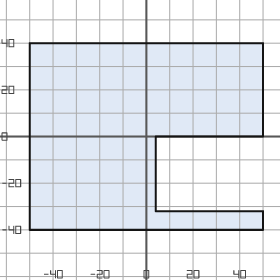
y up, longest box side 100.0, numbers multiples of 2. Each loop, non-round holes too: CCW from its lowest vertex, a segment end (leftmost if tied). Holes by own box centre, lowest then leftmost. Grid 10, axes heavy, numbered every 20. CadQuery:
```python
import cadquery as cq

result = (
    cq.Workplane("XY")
    .moveTo(-50.0, -40.0)
    .lineTo(50.0, -40.0)
    .lineTo(50.0, -32.0)
    .lineTo(4.0, -32.0)
    .lineTo(4.0, 0.0)
    .lineTo(50.0, 0.0)
    .lineTo(50.0, 40.0)
    .lineTo(-50.0, 40.0)
    .close()
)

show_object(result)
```